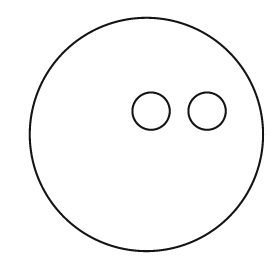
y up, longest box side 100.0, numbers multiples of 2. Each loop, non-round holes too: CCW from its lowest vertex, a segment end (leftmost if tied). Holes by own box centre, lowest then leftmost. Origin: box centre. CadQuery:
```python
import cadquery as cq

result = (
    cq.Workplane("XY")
    .moveTo(0.0, 0.0)
    .circle(50.0)
    .moveTo(2.0, 10.0)
    .circle(8.0)
    .moveTo(26.0, 10.0)
    .circle(8.0)
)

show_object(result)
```